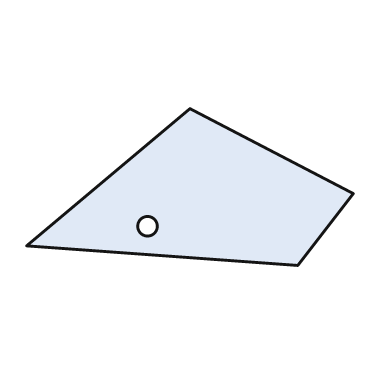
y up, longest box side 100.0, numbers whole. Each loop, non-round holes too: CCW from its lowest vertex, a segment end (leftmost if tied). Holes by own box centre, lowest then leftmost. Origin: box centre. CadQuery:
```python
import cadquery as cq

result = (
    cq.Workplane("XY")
    .moveTo(33.0, -24.0)
    .lineTo(50.0, -2.0)
    .lineTo(0.0, 24.0)
    .lineTo(-50.0, -18.0)
    .close()
    .moveTo(-13.0, -12.0)
    .circle(3.0)
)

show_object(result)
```